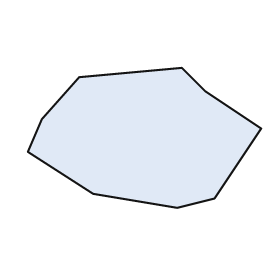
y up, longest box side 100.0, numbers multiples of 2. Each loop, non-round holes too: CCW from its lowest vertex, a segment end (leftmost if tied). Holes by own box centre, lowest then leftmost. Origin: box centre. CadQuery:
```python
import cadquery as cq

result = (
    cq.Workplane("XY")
    .moveTo(14.0, -30.0)
    .lineTo(30.0, -26.0)
    .lineTo(50.0, 4.0)
    .lineTo(26.0, 20.0)
    .lineTo(16.0, 30.0)
    .lineTo(-28.0, 26.0)
    .lineTo(-44.0, 8.0)
    .lineTo(-50.0, -6.0)
    .lineTo(-22.0, -24.0)
    .close()
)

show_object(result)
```